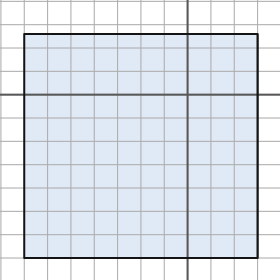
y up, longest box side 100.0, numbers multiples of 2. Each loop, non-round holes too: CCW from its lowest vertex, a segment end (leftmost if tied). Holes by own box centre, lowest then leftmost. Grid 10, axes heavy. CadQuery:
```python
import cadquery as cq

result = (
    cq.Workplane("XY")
    .moveTo(-70.0, -70.0)
    .lineTo(30.0, -70.0)
    .lineTo(30.0, 26.0)
    .lineTo(-70.0, 26.0)
    .close()
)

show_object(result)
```